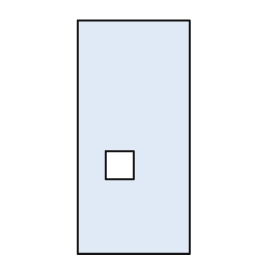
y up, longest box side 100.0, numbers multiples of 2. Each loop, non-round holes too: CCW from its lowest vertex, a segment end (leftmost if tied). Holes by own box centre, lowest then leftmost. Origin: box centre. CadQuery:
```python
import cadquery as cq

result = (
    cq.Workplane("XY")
    .moveTo(-24.0, -50.0)
    .lineTo(24.0, -50.0)
    .lineTo(24.0, 50.0)
    .lineTo(-24.0, 50.0)
    .close()
    .moveTo(-12.0, -18.0)
    .lineTo(0.0, -18.0)
    .lineTo(0.0, -6.0)
    .lineTo(-12.0, -6.0)
    .close()
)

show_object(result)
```